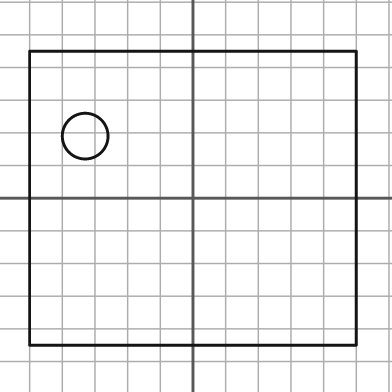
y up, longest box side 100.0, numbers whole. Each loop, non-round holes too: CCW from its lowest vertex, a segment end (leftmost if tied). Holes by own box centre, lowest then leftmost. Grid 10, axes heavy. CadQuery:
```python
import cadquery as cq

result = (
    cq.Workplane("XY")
    .moveTo(-50.0, -45.0)
    .lineTo(50.0, -45.0)
    .lineTo(50.0, 45.0)
    .lineTo(-50.0, 45.0)
    .close()
    .moveTo(-33.0, 19.0)
    .circle(7.0)
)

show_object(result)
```